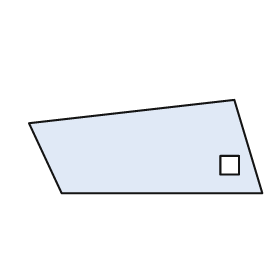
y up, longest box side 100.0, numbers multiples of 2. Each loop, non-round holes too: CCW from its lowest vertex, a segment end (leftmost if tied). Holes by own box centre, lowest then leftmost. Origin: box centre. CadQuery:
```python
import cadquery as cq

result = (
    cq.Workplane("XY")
    .moveTo(-36.0, -20.0)
    .lineTo(50.0, -20.0)
    .lineTo(38.0, 20.0)
    .lineTo(-50.0, 10.0)
    .close()
    .moveTo(32.0, -12.0)
    .lineTo(40.0, -12.0)
    .lineTo(40.0, -4.0)
    .lineTo(32.0, -4.0)
    .close()
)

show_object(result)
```